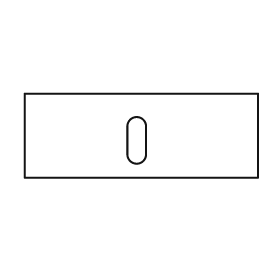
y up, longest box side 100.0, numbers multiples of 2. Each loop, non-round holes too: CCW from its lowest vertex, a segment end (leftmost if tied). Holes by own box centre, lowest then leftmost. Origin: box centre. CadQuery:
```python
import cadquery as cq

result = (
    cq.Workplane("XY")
    .moveTo(-50.0, -18.0)
    .lineTo(50.0, -18.0)
    .lineTo(50.0, 18.0)
    .lineTo(-50.0, 18.0)
    .close()
    .moveTo(-6.0, -8.0)
    .threePointArc((-2.0, -12.0), (2.0, -8.0))
    .lineTo(2.0, 4.0)
    .threePointArc((-2.0, 8.0), (-6.0, 4.0))
    .close()
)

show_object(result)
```